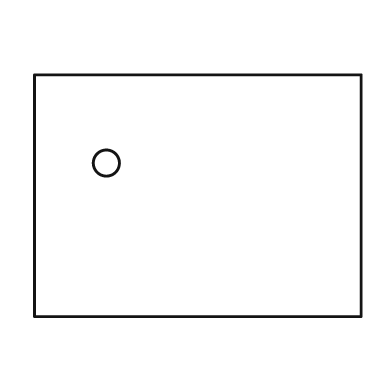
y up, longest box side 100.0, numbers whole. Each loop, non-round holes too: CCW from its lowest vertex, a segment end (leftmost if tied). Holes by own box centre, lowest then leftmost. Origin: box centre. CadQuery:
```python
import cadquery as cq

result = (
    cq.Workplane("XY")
    .moveTo(-50.0, -37.0)
    .lineTo(50.0, -37.0)
    .lineTo(50.0, 37.0)
    .lineTo(-50.0, 37.0)
    .close()
    .moveTo(-28.0, 10.0)
    .circle(4.0)
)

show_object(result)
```